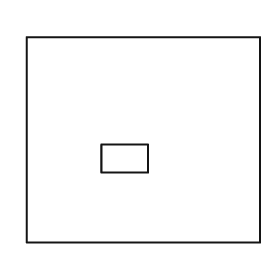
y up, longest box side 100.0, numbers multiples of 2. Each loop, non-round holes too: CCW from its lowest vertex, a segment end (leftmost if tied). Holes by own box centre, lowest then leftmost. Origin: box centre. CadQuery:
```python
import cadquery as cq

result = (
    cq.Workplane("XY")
    .moveTo(-50.0, -44.0)
    .lineTo(50.0, -44.0)
    .lineTo(50.0, 44.0)
    .lineTo(-50.0, 44.0)
    .close()
    .moveTo(-18.0, -14.0)
    .lineTo(2.0, -14.0)
    .lineTo(2.0, -2.0)
    .lineTo(-18.0, -2.0)
    .close()
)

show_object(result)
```